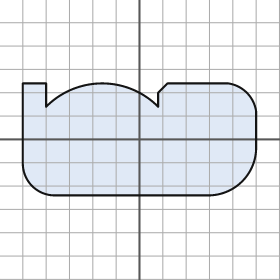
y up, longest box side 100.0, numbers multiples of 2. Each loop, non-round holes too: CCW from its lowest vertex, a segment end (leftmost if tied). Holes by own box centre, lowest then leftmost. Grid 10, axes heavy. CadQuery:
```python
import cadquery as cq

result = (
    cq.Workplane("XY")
    .moveTo(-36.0, -24.0)
    .lineTo(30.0, -24.0)
    .threePointArc((44.0, -18.0), (50.0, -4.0))
    .lineTo(50.0, 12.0)
    .threePointArc((46.0, 20.0), (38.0, 24.0))
    .lineTo(12.0, 24.0)
    .lineTo(8.0, 20.0)
    .lineTo(8.0, 14.0)
    .threePointArc((-16.0, 24.0), (-40.0, 14.0))
    .lineTo(-40.0, 24.0)
    .lineTo(-50.0, 24.0)
    .lineTo(-50.0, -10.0)
    .threePointArc((-46.0, -20.0), (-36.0, -24.0))
    .close()
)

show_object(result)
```